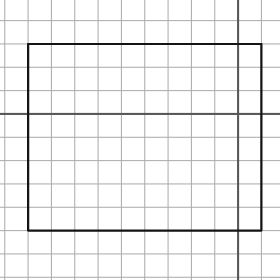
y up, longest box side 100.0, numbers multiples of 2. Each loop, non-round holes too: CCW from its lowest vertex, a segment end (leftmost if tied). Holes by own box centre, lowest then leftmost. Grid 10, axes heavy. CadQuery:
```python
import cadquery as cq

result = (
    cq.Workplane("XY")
    .moveTo(-90.0, -50.0)
    .lineTo(10.0, -50.0)
    .lineTo(10.0, 30.0)
    .lineTo(-90.0, 30.0)
    .close()
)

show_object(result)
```